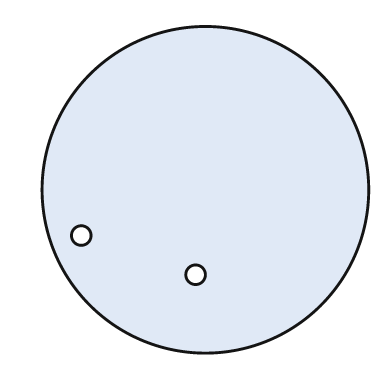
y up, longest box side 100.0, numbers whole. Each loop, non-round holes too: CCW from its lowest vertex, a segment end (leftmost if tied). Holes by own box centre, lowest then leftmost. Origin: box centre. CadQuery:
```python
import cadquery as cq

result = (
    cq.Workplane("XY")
    .moveTo(0.0, 0.0)
    .circle(50.0)
    .moveTo(-3.0, -26.0)
    .circle(3.0)
    .moveTo(-38.0, -14.0)
    .circle(3.0)
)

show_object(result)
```